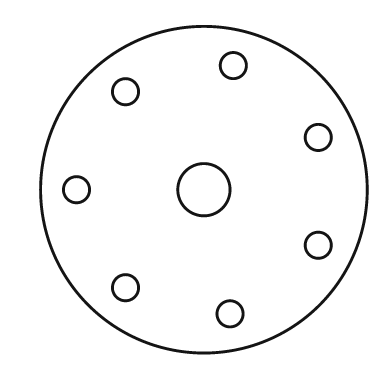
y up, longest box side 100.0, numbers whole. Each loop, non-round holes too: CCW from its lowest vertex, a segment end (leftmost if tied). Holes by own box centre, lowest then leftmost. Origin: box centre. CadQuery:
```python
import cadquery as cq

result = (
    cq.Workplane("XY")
    .moveTo(0.0, 0.0)
    .circle(50.0)
    .moveTo(8.0, -38.0)
    .circle(4.0)
    .moveTo(-24.0, -30.0)
    .circle(4.0)
    .moveTo(35.0, -17.0)
    .circle(4.0)
    .moveTo(-39.0, 0.0)
    .circle(4.0)
    .moveTo(0.0, 0.0)
    .circle(8.0)
    .moveTo(35.0, 16.0)
    .circle(4.0)
    .moveTo(-24.0, 30.0)
    .circle(4.0)
    .moveTo(9.0, 38.0)
    .circle(4.0)
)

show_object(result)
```